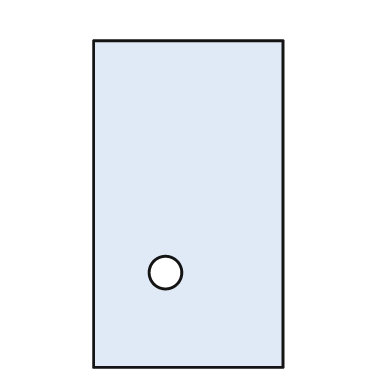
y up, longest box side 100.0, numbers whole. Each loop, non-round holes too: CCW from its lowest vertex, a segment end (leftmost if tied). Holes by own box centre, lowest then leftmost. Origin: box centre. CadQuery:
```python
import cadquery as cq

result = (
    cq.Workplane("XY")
    .moveTo(-29.0, -50.0)
    .lineTo(29.0, -50.0)
    .lineTo(29.0, 50.0)
    .lineTo(-29.0, 50.0)
    .close()
    .moveTo(-7.0, -21.0)
    .circle(5.0)
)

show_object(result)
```